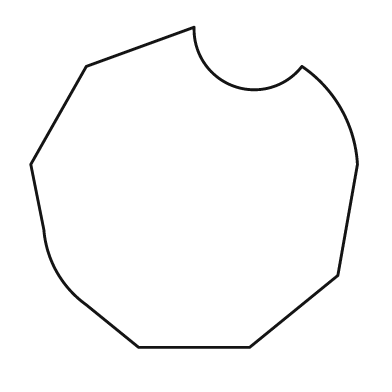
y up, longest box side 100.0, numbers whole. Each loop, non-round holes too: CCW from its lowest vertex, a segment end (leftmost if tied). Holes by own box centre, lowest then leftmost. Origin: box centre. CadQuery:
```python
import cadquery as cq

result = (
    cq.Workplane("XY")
    .moveTo(-17.0, -49.0)
    .lineTo(17.0, -49.0)
    .lineTo(44.0, -27.0)
    .lineTo(50.0, 7.0)
    .threePointArc((45.0, 24.0), (33.0, 37.0))
    .threePointArc((12.0, 31.0), (0.0, 49.0))
    .lineTo(-33.0, 37.0)
    .lineTo(-50.0, 7.0)
    .lineTo(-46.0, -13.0)
    .threePointArc((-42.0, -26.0), (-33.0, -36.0))
    .close()
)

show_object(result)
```